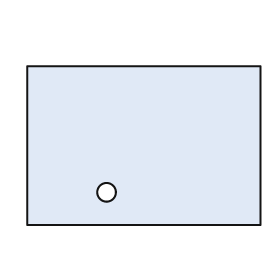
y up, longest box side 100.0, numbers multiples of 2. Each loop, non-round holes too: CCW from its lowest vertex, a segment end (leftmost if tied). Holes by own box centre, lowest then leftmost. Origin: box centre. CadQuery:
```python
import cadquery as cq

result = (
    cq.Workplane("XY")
    .moveTo(-50.0, -34.0)
    .lineTo(50.0, -34.0)
    .lineTo(50.0, 34.0)
    .lineTo(-50.0, 34.0)
    .close()
    .moveTo(-16.0, -20.0)
    .circle(4.0)
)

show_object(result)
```